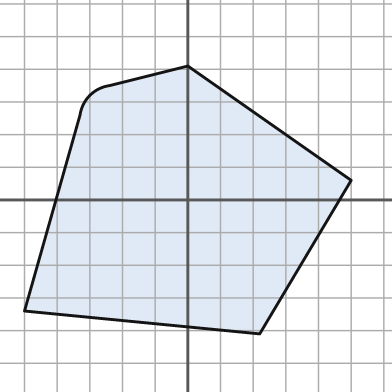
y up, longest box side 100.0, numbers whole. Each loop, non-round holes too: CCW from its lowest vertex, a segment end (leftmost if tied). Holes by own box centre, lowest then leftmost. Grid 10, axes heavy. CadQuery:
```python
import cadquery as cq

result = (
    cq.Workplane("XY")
    .moveTo(22.0, -41.0)
    .lineTo(50.0, 6.0)
    .lineTo(0.0, 41.0)
    .lineTo(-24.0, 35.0)
    .threePointArc((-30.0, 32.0), (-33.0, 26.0))
    .lineTo(-50.0, -34.0)
    .close()
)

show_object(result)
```